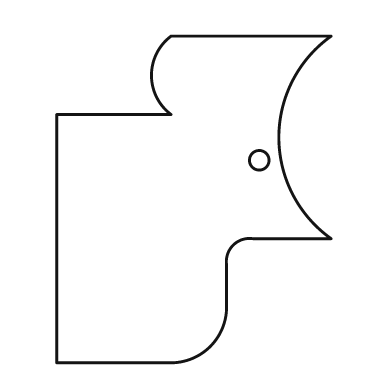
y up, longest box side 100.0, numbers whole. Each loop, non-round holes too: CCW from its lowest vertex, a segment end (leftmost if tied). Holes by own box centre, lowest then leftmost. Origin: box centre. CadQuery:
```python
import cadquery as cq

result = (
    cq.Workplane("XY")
    .moveTo(-42.0, -50.0)
    .lineTo(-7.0, -50.0)
    .threePointArc((5.0, -45.0), (10.0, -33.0))
    .lineTo(10.0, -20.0)
    .threePointArc((12.0, -14.0), (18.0, -12.0))
    .lineTo(42.0, -12.0)
    .threePointArc((26.0, 19.0), (42.0, 50.0))
    .lineTo(-7.0, 50.0)
    .threePointArc((-13.0, 38.0), (-7.0, 26.0))
    .lineTo(-42.0, 26.0)
    .close()
    .moveTo(20.0, 12.0)
    .circle(3.0)
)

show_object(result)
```